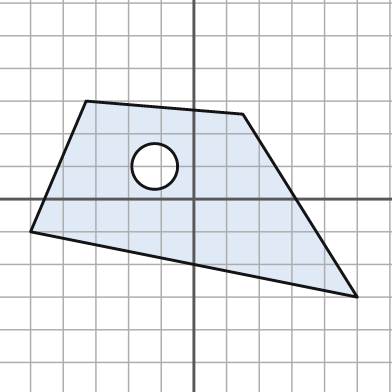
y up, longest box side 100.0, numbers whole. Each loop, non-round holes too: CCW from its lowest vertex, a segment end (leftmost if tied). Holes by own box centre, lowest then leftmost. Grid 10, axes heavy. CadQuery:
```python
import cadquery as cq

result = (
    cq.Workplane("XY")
    .moveTo(50.0, -30.0)
    .lineTo(15.0, 26.0)
    .lineTo(-33.0, 30.0)
    .lineTo(-50.0, -10.0)
    .close()
    .moveTo(-12.0, 10.0)
    .circle(7.0)
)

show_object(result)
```